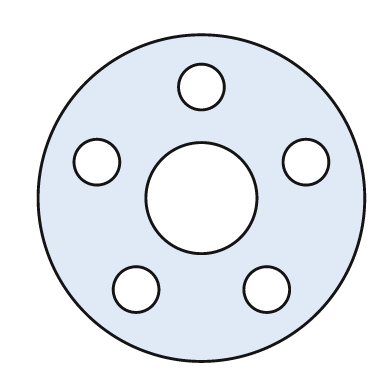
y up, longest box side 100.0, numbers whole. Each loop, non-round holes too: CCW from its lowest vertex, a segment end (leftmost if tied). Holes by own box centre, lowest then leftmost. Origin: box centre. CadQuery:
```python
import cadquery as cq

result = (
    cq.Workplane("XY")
    .moveTo(0.0, 0.0)
    .circle(50.0)
    .moveTo(-20.0, -28.0)
    .circle(7.0)
    .moveTo(20.0, -28.0)
    .circle(7.0)
    .moveTo(0.0, 0.0)
    .circle(17.0)
    .moveTo(-32.0, 11.0)
    .circle(7.0)
    .moveTo(32.0, 11.0)
    .circle(7.0)
    .moveTo(0.0, 34.0)
    .circle(7.0)
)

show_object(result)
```